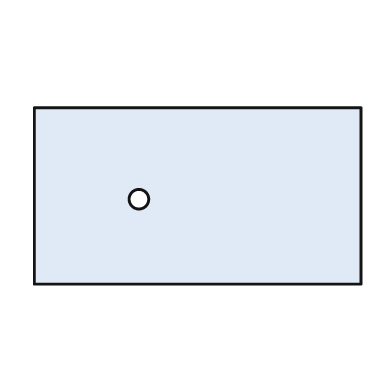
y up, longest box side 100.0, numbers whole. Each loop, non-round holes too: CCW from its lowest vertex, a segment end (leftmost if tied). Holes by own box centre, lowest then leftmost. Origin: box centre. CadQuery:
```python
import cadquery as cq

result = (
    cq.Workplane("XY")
    .moveTo(-50.0, -27.0)
    .lineTo(50.0, -27.0)
    .lineTo(50.0, 27.0)
    .lineTo(-50.0, 27.0)
    .close()
    .moveTo(-18.0, -1.0)
    .circle(3.0)
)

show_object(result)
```